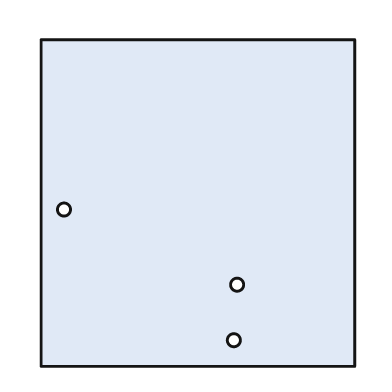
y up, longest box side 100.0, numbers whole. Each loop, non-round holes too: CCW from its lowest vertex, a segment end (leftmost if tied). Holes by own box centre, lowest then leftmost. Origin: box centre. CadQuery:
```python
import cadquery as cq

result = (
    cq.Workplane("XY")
    .moveTo(-48.0, -50.0)
    .lineTo(48.0, -50.0)
    .lineTo(48.0, 50.0)
    .lineTo(-48.0, 50.0)
    .close()
    .moveTo(11.0, -42.0)
    .circle(2.0)
    .moveTo(12.0, -25.0)
    .circle(2.0)
    .moveTo(-41.0, -2.0)
    .circle(2.0)
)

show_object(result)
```